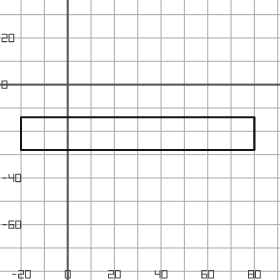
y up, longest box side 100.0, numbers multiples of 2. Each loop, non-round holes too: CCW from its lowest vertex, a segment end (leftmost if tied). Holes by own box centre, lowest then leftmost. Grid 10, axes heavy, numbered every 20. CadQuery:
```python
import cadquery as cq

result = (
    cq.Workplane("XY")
    .moveTo(-20.0, -28.0)
    .lineTo(80.0, -28.0)
    .lineTo(80.0, -14.0)
    .lineTo(-20.0, -14.0)
    .close()
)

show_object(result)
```